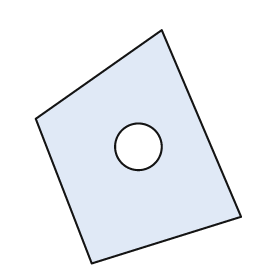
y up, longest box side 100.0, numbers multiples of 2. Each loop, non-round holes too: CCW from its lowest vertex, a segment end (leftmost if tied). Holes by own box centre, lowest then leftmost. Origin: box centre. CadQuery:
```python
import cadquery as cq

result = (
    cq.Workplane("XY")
    .moveTo(-20.0, -50.0)
    .lineTo(44.0, -30.0)
    .lineTo(10.0, 50.0)
    .lineTo(-44.0, 12.0)
    .close()
    .moveTo(0.0, 0.0)
    .circle(10.0)
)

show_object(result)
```